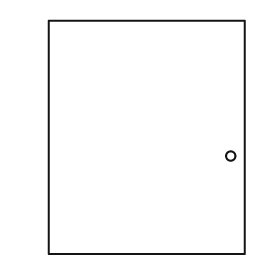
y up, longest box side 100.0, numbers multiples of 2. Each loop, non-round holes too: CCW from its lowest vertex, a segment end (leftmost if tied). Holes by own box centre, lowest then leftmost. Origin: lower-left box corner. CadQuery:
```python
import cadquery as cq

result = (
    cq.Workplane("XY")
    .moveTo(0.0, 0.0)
    .lineTo(84.0, 0.0)
    .lineTo(84.0, 100.0)
    .lineTo(0.0, 100.0)
    .close()
    .moveTo(78.0, 42.0)
    .circle(2.0)
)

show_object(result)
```